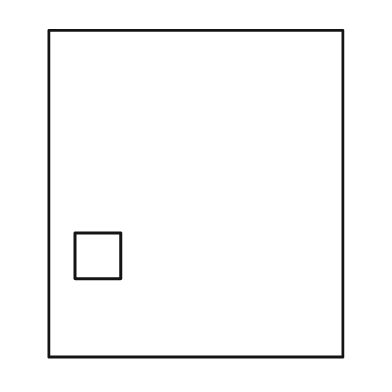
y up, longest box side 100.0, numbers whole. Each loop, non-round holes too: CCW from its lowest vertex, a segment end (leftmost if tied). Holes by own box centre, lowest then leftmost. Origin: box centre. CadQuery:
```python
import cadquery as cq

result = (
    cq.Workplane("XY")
    .moveTo(-45.0, -50.0)
    .lineTo(45.0, -50.0)
    .lineTo(45.0, 50.0)
    .lineTo(-45.0, 50.0)
    .close()
    .moveTo(-37.0, -26.0)
    .lineTo(-23.0, -26.0)
    .lineTo(-23.0, -12.0)
    .lineTo(-37.0, -12.0)
    .close()
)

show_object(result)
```